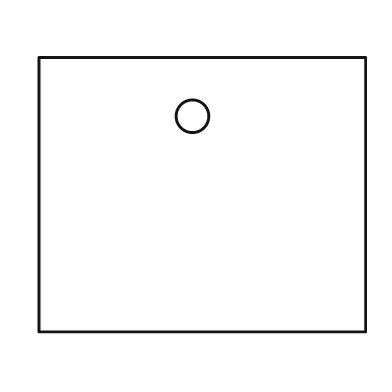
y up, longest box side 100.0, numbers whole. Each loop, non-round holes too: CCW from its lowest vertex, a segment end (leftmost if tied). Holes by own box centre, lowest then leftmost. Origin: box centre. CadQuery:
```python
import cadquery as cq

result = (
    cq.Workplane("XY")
    .moveTo(-50.0, -42.0)
    .lineTo(50.0, -42.0)
    .lineTo(50.0, 42.0)
    .lineTo(-50.0, 42.0)
    .close()
    .moveTo(-3.0, 24.0)
    .circle(5.0)
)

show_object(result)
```